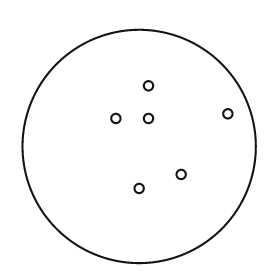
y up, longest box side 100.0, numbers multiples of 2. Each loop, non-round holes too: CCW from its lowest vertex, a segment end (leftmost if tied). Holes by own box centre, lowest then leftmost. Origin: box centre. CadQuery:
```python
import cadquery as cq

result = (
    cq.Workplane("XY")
    .moveTo(0.0, 0.0)
    .circle(50.0)
    .moveTo(0.0, -18.0)
    .circle(2.0)
    .moveTo(18.0, -12.0)
    .circle(2.0)
    .moveTo(-10.0, 12.0)
    .circle(2.0)
    .moveTo(4.0, 12.0)
    .circle(2.0)
    .moveTo(38.0, 14.0)
    .circle(2.0)
    .moveTo(4.0, 26.0)
    .circle(2.0)
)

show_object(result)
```